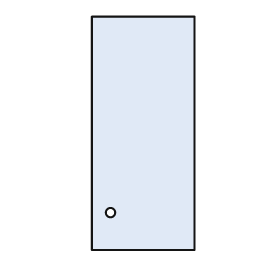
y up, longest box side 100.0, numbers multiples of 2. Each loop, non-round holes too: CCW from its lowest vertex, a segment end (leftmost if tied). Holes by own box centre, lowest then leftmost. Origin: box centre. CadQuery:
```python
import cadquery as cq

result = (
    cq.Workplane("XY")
    .moveTo(-22.0, -50.0)
    .lineTo(22.0, -50.0)
    .lineTo(22.0, 50.0)
    .lineTo(-22.0, 50.0)
    .close()
    .moveTo(-14.0, -34.0)
    .circle(2.0)
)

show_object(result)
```